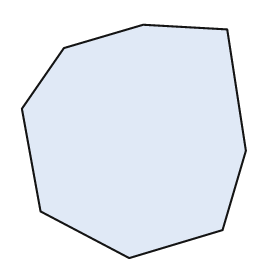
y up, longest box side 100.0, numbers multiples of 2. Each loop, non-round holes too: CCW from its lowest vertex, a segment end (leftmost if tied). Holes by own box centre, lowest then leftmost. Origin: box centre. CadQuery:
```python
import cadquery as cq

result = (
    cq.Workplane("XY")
    .moveTo(-2.0, -50.0)
    .lineTo(38.0, -38.0)
    .lineTo(48.0, -4.0)
    .lineTo(40.0, 48.0)
    .lineTo(4.0, 50.0)
    .lineTo(-30.0, 40.0)
    .lineTo(-48.0, 14.0)
    .lineTo(-40.0, -30.0)
    .close()
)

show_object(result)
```